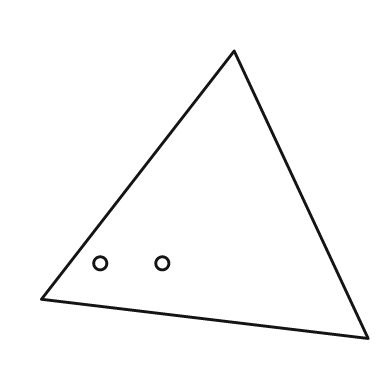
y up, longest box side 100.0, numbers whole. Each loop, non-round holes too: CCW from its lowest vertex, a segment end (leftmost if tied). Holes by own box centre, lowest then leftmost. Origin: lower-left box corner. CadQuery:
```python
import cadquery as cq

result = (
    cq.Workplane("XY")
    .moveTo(100.0, 0.0)
    .lineTo(59.0, 88.0)
    .lineTo(0.0, 12.0)
    .close()
    .moveTo(18.0, 23.0)
    .circle(2.0)
    .moveTo(37.0, 23.0)
    .circle(2.0)
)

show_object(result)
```